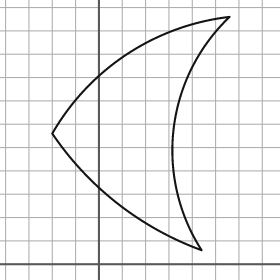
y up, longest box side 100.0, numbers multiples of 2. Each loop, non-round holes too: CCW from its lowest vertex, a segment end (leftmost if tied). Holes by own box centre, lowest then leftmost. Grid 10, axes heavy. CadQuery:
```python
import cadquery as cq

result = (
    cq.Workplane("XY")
    .moveTo(44.0, 6.0)
    .threePointArc((32.0, 58.0), (56.0, 106.0))
    .threePointArc((12.0, 90.0), (-20.0, 56.0))
    .threePointArc((8.0, 26.0), (44.0, 6.0))
    .close()
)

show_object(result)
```